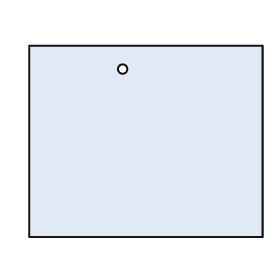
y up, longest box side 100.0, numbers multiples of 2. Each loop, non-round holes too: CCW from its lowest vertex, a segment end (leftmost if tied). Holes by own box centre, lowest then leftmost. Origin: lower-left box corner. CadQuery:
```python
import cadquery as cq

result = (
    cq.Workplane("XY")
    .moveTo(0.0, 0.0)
    .lineTo(100.0, 0.0)
    .lineTo(100.0, 82.0)
    .lineTo(0.0, 82.0)
    .close()
    .moveTo(40.0, 72.0)
    .circle(2.0)
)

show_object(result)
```